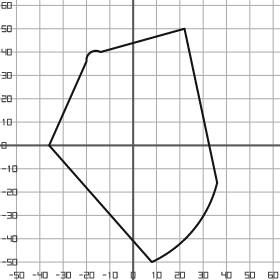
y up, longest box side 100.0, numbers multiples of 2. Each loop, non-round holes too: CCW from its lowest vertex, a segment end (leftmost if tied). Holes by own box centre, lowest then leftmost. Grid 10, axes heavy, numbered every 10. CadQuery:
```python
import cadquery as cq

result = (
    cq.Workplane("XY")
    .moveTo(8.0, -50.0)
    .threePointArc((26.0, -36.0), (36.0, -16.0))
    .lineTo(22.0, 50.0)
    .lineTo(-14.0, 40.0)
    .threePointArc((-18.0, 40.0), (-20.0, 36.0))
    .lineTo(-36.0, 0.0)
    .close()
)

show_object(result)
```